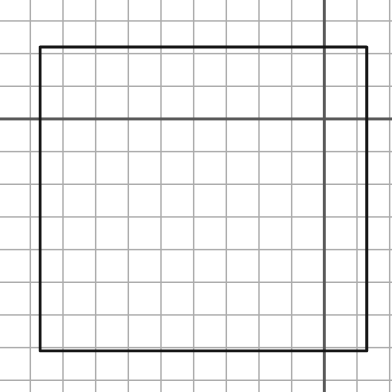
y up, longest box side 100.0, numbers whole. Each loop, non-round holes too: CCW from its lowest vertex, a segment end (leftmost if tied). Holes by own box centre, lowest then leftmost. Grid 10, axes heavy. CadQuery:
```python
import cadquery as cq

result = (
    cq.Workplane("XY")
    .moveTo(-87.0, -71.0)
    .lineTo(13.0, -71.0)
    .lineTo(13.0, 22.0)
    .lineTo(-87.0, 22.0)
    .close()
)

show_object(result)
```